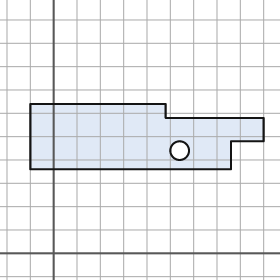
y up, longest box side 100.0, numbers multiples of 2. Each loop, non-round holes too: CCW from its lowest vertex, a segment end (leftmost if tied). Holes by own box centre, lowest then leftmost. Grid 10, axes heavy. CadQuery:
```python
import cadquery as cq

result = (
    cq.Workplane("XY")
    .moveTo(-10.0, 36.0)
    .lineTo(76.0, 36.0)
    .lineTo(76.0, 48.0)
    .lineTo(90.0, 48.0)
    .lineTo(90.0, 58.0)
    .lineTo(48.0, 58.0)
    .lineTo(48.0, 64.0)
    .lineTo(-10.0, 64.0)
    .close()
    .moveTo(54.0, 44.0)
    .circle(4.0)
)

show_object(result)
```